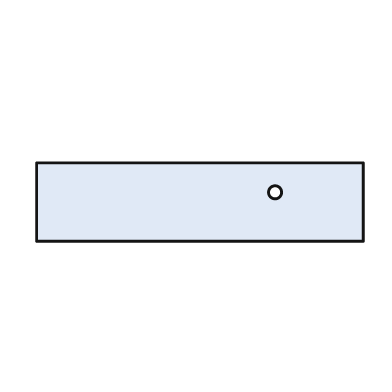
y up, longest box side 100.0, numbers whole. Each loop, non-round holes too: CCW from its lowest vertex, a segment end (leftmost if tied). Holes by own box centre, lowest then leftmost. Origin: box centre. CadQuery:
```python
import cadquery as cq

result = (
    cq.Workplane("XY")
    .moveTo(-50.0, -12.0)
    .lineTo(50.0, -12.0)
    .lineTo(50.0, 12.0)
    .lineTo(-50.0, 12.0)
    .close()
    .moveTo(23.0, 3.0)
    .circle(2.0)
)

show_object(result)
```